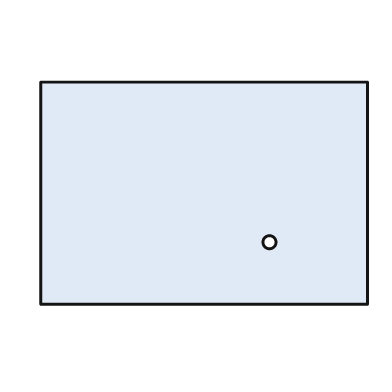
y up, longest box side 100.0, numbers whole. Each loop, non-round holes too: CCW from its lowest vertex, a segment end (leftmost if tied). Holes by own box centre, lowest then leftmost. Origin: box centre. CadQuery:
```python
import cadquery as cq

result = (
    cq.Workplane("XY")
    .moveTo(-50.0, -34.0)
    .lineTo(50.0, -34.0)
    .lineTo(50.0, 34.0)
    .lineTo(-50.0, 34.0)
    .close()
    .moveTo(20.0, -15.0)
    .circle(2.0)
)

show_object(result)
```